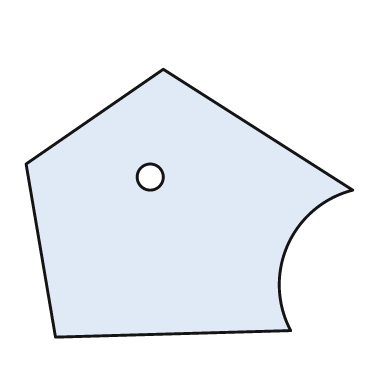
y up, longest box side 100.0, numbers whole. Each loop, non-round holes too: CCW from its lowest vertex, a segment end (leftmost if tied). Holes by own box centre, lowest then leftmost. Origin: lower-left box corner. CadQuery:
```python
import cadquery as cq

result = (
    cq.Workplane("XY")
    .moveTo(9.0, 0.0)
    .lineTo(81.0, 2.0)
    .threePointArc((80.0, 28.0), (100.0, 45.0))
    .lineTo(42.0, 82.0)
    .lineTo(0.0, 53.0)
    .close()
    .moveTo(38.0, 49.0)
    .circle(4.0)
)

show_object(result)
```